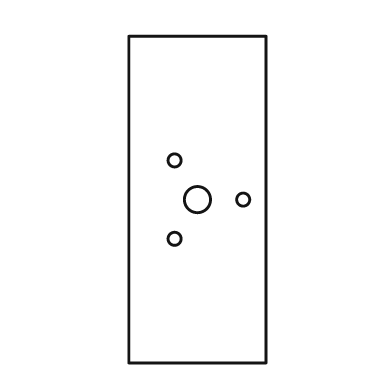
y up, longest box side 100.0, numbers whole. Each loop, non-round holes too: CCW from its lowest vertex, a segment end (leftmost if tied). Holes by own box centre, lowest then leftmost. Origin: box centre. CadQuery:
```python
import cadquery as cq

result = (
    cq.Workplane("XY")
    .moveTo(-21.0, -50.0)
    .lineTo(21.0, -50.0)
    .lineTo(21.0, 50.0)
    .lineTo(-21.0, 50.0)
    .close()
    .moveTo(-7.0, -12.0)
    .circle(2.0)
    .moveTo(0.0, 0.0)
    .circle(4.0)
    .moveTo(14.0, 0.0)
    .circle(2.0)
    .moveTo(-7.0, 12.0)
    .circle(2.0)
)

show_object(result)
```